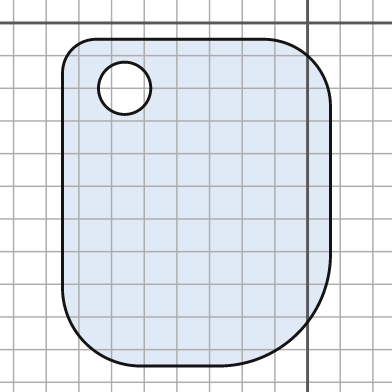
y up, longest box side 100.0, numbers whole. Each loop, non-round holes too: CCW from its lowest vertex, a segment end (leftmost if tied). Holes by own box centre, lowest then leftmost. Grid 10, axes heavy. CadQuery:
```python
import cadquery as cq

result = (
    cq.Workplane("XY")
    .moveTo(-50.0, -105.0)
    .lineTo(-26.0, -105.0)
    .threePointArc((-3.0, -95.0), (7.0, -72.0))
    .lineTo(7.0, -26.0)
    .threePointArc((1.0, -11.0), (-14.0, -5.0))
    .lineTo(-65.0, -5.0)
    .threePointArc((-72.0, -8.0), (-75.0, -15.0))
    .lineTo(-75.0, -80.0)
    .threePointArc((-68.0, -98.0), (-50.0, -105.0))
    .close()
    .moveTo(-56.0, -20.0)
    .circle(8.0)
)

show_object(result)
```